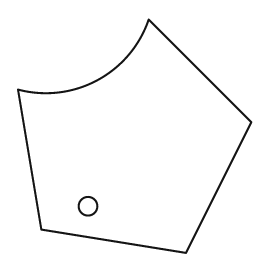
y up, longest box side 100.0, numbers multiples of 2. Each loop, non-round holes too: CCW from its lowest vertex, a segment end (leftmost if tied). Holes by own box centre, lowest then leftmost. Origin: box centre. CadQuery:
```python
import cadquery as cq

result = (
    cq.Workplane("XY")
    .moveTo(22.0, -50.0)
    .lineTo(50.0, 6.0)
    .lineTo(6.0, 50.0)
    .threePointArc((-16.0, 24.0), (-50.0, 20.0))
    .lineTo(-40.0, -40.0)
    .close()
    .moveTo(-20.0, -30.0)
    .circle(4.0)
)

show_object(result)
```